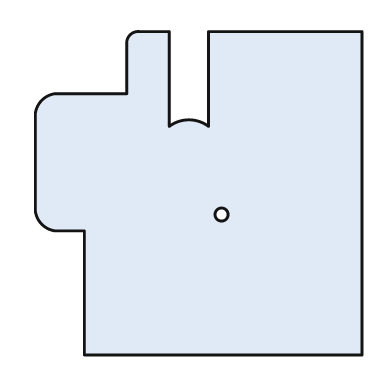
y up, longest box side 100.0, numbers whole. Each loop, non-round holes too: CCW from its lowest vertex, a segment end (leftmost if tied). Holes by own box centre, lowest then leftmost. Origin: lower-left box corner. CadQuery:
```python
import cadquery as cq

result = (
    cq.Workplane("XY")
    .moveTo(15.0, 0.0)
    .lineTo(100.0, 0.0)
    .lineTo(100.0, 99.0)
    .lineTo(53.0, 99.0)
    .lineTo(53.0, 70.0)
    .threePointArc((47.0, 72.0), (41.0, 70.0))
    .lineTo(41.0, 99.0)
    .lineTo(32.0, 99.0)
    .threePointArc((29.0, 98.0), (28.0, 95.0))
    .lineTo(28.0, 80.0)
    .lineTo(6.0, 80.0)
    .threePointArc((2.0, 78.0), (0.0, 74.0))
    .lineTo(0.0, 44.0)
    .threePointArc((2.0, 40.0), (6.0, 38.0))
    .lineTo(15.0, 38.0)
    .close()
    .moveTo(57.0, 43.0)
    .circle(2.0)
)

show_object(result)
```